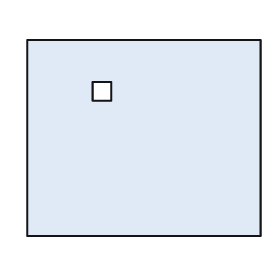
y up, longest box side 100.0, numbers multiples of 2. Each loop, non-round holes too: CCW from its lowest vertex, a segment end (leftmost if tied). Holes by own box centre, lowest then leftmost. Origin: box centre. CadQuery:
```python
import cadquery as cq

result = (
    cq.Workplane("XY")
    .moveTo(-50.0, -42.0)
    .lineTo(50.0, -42.0)
    .lineTo(50.0, 42.0)
    .lineTo(-50.0, 42.0)
    .close()
    .moveTo(-22.0, 16.0)
    .lineTo(-14.0, 16.0)
    .lineTo(-14.0, 24.0)
    .lineTo(-22.0, 24.0)
    .close()
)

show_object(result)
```